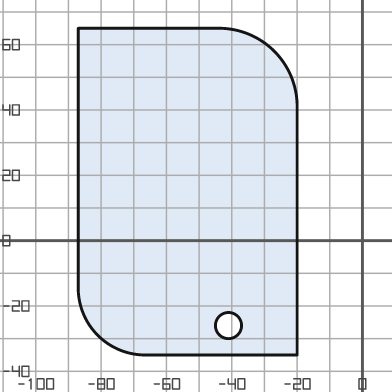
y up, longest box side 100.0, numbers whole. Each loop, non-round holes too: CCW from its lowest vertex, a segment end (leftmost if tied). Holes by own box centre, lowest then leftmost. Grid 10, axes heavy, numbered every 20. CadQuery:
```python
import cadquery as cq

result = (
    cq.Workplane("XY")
    .moveTo(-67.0, -35.0)
    .lineTo(-20.0, -35.0)
    .lineTo(-20.0, 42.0)
    .threePointArc((-27.0, 58.0), (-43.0, 65.0))
    .lineTo(-87.0, 65.0)
    .lineTo(-87.0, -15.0)
    .threePointArc((-81.0, -29.0), (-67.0, -35.0))
    .close()
    .moveTo(-41.0, -26.0)
    .circle(4.0)
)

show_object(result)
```